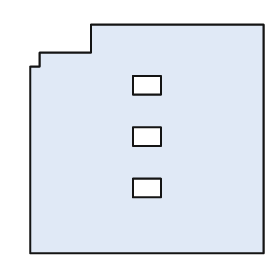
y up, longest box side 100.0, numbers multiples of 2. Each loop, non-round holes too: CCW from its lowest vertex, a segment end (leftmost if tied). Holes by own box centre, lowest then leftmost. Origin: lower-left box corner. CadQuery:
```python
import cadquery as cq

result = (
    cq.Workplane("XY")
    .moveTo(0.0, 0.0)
    .lineTo(100.0, 0.0)
    .lineTo(100.0, 98.0)
    .lineTo(26.0, 98.0)
    .lineTo(26.0, 86.0)
    .lineTo(4.0, 86.0)
    .lineTo(4.0, 80.0)
    .lineTo(0.0, 80.0)
    .close()
    .moveTo(44.0, 24.0)
    .lineTo(56.0, 24.0)
    .lineTo(56.0, 32.0)
    .lineTo(44.0, 32.0)
    .close()
    .moveTo(44.0, 46.0)
    .lineTo(56.0, 46.0)
    .lineTo(56.0, 54.0)
    .lineTo(44.0, 54.0)
    .close()
    .moveTo(44.0, 68.0)
    .lineTo(56.0, 68.0)
    .lineTo(56.0, 76.0)
    .lineTo(44.0, 76.0)
    .close()
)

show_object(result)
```